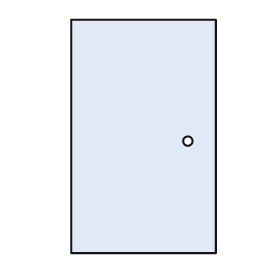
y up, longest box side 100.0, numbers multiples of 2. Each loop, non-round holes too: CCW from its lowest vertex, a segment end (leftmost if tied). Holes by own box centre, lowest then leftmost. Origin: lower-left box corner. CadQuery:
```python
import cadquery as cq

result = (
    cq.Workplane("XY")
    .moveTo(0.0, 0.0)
    .lineTo(62.0, 0.0)
    .lineTo(62.0, 100.0)
    .lineTo(0.0, 100.0)
    .close()
    .moveTo(50.0, 48.0)
    .circle(2.0)
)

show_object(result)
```